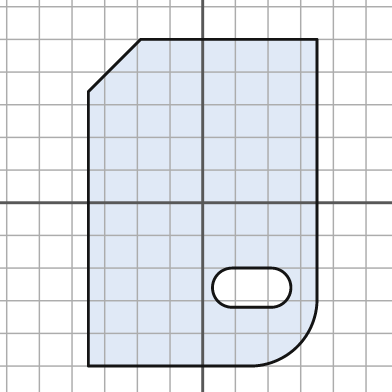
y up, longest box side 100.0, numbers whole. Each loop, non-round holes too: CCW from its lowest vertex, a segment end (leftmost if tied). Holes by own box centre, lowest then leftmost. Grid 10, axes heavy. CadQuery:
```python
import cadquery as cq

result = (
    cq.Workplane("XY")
    .moveTo(-35.0, -50.0)
    .lineTo(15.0, -50.0)
    .threePointArc((29.0, -44.0), (35.0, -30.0))
    .lineTo(35.0, 50.0)
    .lineTo(-19.0, 50.0)
    .lineTo(-35.0, 34.0)
    .close()
    .moveTo(9.0, -32.0)
    .lineTo(21.0, -32.0)
    .threePointArc((27.0, -26.0), (21.0, -20.0))
    .lineTo(9.0, -20.0)
    .threePointArc((3.0, -26.0), (9.0, -32.0))
    .close()
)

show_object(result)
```